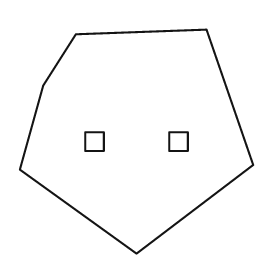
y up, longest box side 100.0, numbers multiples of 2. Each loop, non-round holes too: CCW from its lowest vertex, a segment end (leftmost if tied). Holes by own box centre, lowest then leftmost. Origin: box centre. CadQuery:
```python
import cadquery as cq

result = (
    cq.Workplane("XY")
    .moveTo(0.0, -48.0)
    .lineTo(50.0, -10.0)
    .lineTo(30.0, 48.0)
    .lineTo(-26.0, 46.0)
    .lineTo(-40.0, 24.0)
    .lineTo(-50.0, -12.0)
    .close()
    .moveTo(-22.0, -4.0)
    .lineTo(-14.0, -4.0)
    .lineTo(-14.0, 4.0)
    .lineTo(-22.0, 4.0)
    .close()
    .moveTo(14.0, -4.0)
    .lineTo(22.0, -4.0)
    .lineTo(22.0, 4.0)
    .lineTo(14.0, 4.0)
    .close()
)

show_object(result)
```